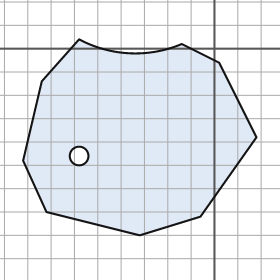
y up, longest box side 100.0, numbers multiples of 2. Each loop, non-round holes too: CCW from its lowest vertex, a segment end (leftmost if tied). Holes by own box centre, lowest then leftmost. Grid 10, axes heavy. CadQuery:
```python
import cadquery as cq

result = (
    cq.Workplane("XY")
    .moveTo(-32.0, -80.0)
    .lineTo(-6.0, -72.0)
    .lineTo(18.0, -38.0)
    .lineTo(2.0, -6.0)
    .lineTo(-14.0, 2.0)
    .threePointArc((-36.0, -2.0), (-58.0, 4.0))
    .lineTo(-74.0, -14.0)
    .lineTo(-82.0, -48.0)
    .lineTo(-72.0, -70.0)
    .close()
    .moveTo(-58.0, -46.0)
    .circle(4.0)
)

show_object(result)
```